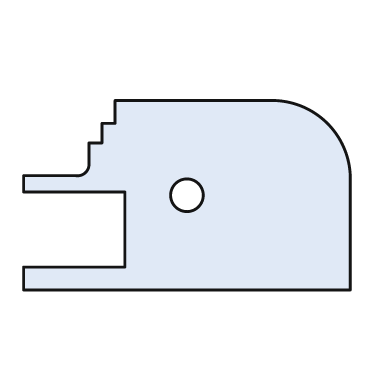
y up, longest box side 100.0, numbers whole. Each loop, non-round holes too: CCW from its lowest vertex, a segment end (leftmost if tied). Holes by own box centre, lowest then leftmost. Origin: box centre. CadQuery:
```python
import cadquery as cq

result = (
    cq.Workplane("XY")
    .moveTo(-50.0, -29.0)
    .lineTo(50.0, -29.0)
    .lineTo(50.0, 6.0)
    .threePointArc((43.0, 22.0), (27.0, 29.0))
    .lineTo(-22.0, 29.0)
    .lineTo(-22.0, 22.0)
    .lineTo(-26.0, 22.0)
    .lineTo(-26.0, 16.0)
    .lineTo(-30.0, 16.0)
    .lineTo(-30.0, 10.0)
    .threePointArc((-31.0, 7.0), (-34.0, 6.0))
    .lineTo(-50.0, 6.0)
    .lineTo(-50.0, 1.0)
    .lineTo(-19.0, 1.0)
    .lineTo(-19.0, -22.0)
    .lineTo(-50.0, -22.0)
    .close()
    .moveTo(0.0, 0.0)
    .circle(5.0)
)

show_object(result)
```